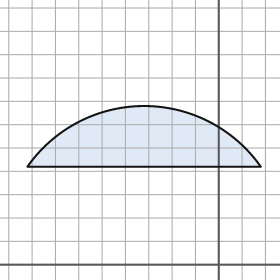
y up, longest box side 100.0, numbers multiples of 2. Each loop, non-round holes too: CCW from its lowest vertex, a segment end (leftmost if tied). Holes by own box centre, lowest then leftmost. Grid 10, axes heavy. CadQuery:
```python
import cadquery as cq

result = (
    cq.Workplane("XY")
    .moveTo(-82.0, 42.0)
    .lineTo(18.0, 42.0)
    .threePointArc((-32.0, 68.0), (-82.0, 42.0))
    .close()
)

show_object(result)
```